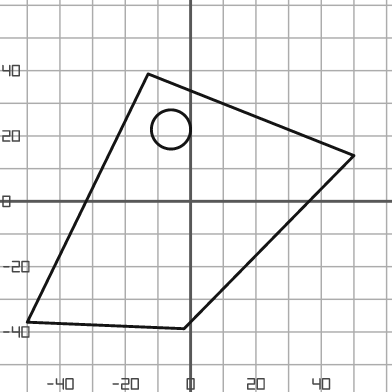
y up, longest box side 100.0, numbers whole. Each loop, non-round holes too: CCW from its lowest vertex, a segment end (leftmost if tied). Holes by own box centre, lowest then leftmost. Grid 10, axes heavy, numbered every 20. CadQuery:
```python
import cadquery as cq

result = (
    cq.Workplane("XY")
    .moveTo(-2.0, -39.0)
    .lineTo(50.0, 14.0)
    .lineTo(-13.0, 39.0)
    .lineTo(-50.0, -37.0)
    .close()
    .moveTo(-6.0, 22.0)
    .circle(6.0)
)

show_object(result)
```